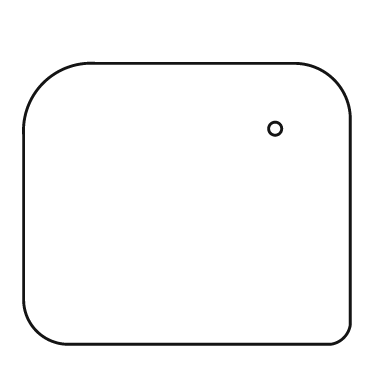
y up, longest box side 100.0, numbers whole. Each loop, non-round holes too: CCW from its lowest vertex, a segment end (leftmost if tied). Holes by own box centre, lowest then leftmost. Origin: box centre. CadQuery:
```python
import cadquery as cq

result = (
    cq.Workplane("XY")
    .moveTo(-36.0, -43.0)
    .lineTo(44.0, -43.0)
    .threePointArc((48.0, -41.0), (50.0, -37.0))
    .lineTo(50.0, 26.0)
    .threePointArc((45.0, 38.0), (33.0, 43.0))
    .lineTo(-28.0, 43.0)
    .threePointArc((-44.0, 37.0), (-50.0, 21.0))
    .lineTo(-50.0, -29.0)
    .threePointArc((-46.0, -39.0), (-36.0, -43.0))
    .close()
    .moveTo(27.0, 23.0)
    .circle(2.0)
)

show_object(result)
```